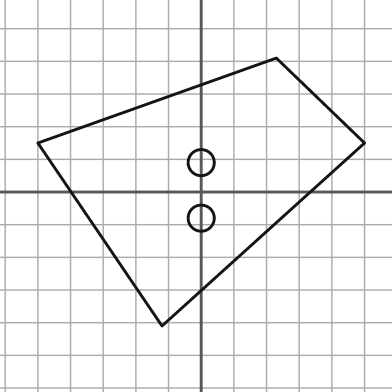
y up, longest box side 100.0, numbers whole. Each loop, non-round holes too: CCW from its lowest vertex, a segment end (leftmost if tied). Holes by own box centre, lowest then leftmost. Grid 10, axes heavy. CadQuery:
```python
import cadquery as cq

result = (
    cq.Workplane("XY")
    .moveTo(-12.0, -41.0)
    .lineTo(50.0, 15.0)
    .lineTo(23.0, 41.0)
    .lineTo(-50.0, 15.0)
    .close()
    .moveTo(0.0, -8.0)
    .circle(4.0)
    .moveTo(0.0, 9.0)
    .circle(4.0)
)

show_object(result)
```